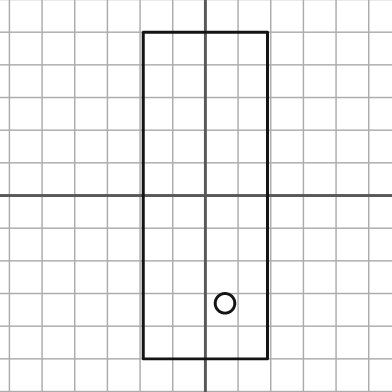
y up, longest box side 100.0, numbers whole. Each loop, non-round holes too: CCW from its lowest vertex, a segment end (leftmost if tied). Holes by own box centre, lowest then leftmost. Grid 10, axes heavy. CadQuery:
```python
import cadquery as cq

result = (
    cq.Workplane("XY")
    .moveTo(-19.0, -50.0)
    .lineTo(19.0, -50.0)
    .lineTo(19.0, 50.0)
    .lineTo(-19.0, 50.0)
    .close()
    .moveTo(6.0, -33.0)
    .circle(3.0)
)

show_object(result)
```